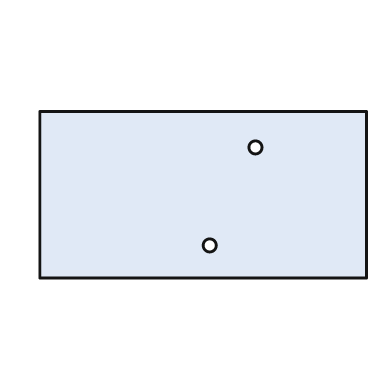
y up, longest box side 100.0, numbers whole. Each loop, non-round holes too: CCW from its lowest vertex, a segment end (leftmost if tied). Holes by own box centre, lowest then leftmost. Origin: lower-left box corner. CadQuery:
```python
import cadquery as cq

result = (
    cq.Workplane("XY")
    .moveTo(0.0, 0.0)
    .lineTo(100.0, 0.0)
    .lineTo(100.0, 51.0)
    .lineTo(0.0, 51.0)
    .close()
    .moveTo(52.0, 10.0)
    .circle(2.0)
    .moveTo(66.0, 40.0)
    .circle(2.0)
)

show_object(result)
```